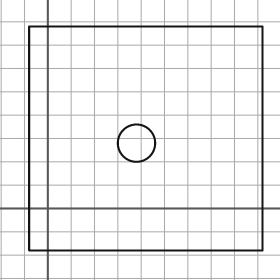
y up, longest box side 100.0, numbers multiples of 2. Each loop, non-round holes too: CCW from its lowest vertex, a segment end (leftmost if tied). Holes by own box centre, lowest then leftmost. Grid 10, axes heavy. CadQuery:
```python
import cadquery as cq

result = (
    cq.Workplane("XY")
    .moveTo(-8.0, -18.0)
    .lineTo(92.0, -18.0)
    .lineTo(92.0, 78.0)
    .lineTo(-8.0, 78.0)
    .close()
    .moveTo(38.0, 28.0)
    .circle(8.0)
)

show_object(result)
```